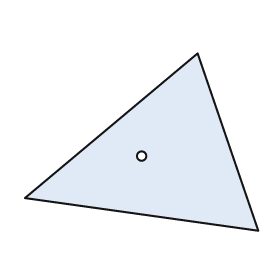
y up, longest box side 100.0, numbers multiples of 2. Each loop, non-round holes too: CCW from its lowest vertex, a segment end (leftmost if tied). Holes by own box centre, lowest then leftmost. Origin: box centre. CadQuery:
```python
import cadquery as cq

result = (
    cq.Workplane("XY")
    .moveTo(50.0, -38.0)
    .lineTo(24.0, 38.0)
    .lineTo(-50.0, -24.0)
    .close()
    .moveTo(0.0, -6.0)
    .circle(2.0)
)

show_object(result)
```